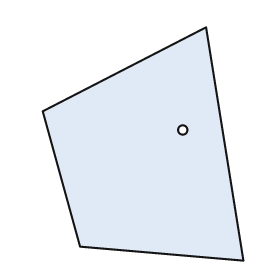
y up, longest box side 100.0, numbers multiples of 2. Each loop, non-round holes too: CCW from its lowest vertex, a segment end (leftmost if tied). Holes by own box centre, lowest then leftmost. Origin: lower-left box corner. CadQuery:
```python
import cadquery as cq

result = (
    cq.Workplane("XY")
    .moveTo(86.0, 0.0)
    .lineTo(70.0, 100.0)
    .lineTo(0.0, 64.0)
    .lineTo(16.0, 6.0)
    .close()
    .moveTo(60.0, 56.0)
    .circle(2.0)
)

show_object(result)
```